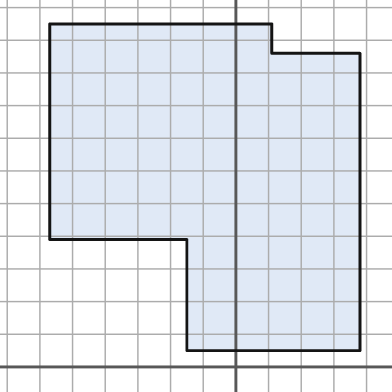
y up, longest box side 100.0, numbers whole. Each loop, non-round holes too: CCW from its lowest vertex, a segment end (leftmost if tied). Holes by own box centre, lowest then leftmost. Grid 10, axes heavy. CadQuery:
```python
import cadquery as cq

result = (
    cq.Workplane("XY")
    .moveTo(-15.0, 5.0)
    .lineTo(38.0, 5.0)
    .lineTo(38.0, 96.0)
    .lineTo(11.0, 96.0)
    .lineTo(11.0, 105.0)
    .lineTo(-57.0, 105.0)
    .lineTo(-57.0, 39.0)
    .lineTo(-15.0, 39.0)
    .close()
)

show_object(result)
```